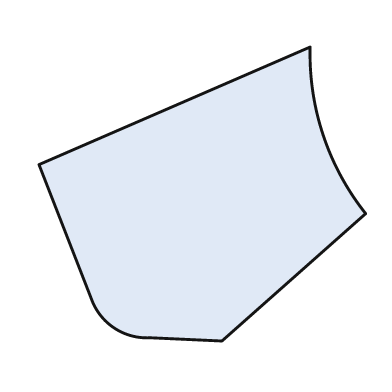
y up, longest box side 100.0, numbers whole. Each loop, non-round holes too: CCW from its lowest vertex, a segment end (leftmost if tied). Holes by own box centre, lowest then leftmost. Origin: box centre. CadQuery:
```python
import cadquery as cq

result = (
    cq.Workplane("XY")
    .moveTo(6.0, -45.0)
    .lineTo(50.0, -6.0)
    .threePointArc((37.0, 18.0), (33.0, 45.0))
    .lineTo(-50.0, 9.0)
    .lineTo(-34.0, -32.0)
    .threePointArc((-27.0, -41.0), (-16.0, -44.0))
    .close()
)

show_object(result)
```